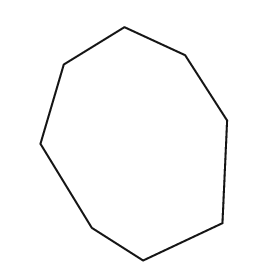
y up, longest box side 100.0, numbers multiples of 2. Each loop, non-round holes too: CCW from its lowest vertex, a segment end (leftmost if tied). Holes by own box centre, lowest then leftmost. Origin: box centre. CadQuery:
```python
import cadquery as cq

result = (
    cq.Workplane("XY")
    .moveTo(4.0, -50.0)
    .lineTo(38.0, -34.0)
    .lineTo(40.0, 10.0)
    .lineTo(22.0, 38.0)
    .lineTo(-4.0, 50.0)
    .lineTo(-30.0, 34.0)
    .lineTo(-40.0, 0.0)
    .lineTo(-18.0, -36.0)
    .close()
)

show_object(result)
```